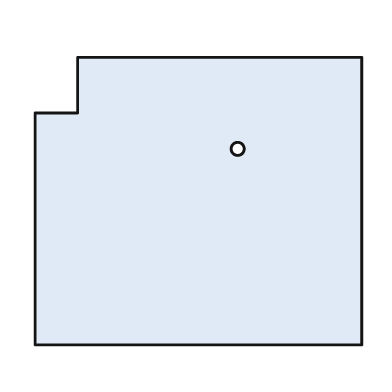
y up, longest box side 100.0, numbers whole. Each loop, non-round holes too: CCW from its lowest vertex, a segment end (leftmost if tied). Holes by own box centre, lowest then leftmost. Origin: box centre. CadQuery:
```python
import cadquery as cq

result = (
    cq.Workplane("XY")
    .moveTo(-50.0, -44.0)
    .lineTo(50.0, -44.0)
    .lineTo(50.0, 44.0)
    .lineTo(-37.0, 44.0)
    .lineTo(-37.0, 27.0)
    .lineTo(-50.0, 27.0)
    .close()
    .moveTo(12.0, 16.0)
    .circle(2.0)
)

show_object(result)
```